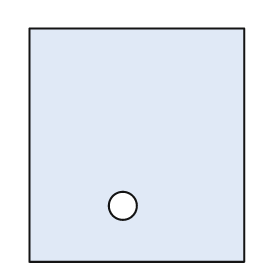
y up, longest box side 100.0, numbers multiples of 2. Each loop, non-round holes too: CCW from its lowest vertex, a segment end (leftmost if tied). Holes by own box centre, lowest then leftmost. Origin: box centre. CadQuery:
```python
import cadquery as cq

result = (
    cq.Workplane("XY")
    .moveTo(-46.0, -50.0)
    .lineTo(46.0, -50.0)
    .lineTo(46.0, 50.0)
    .lineTo(-46.0, 50.0)
    .close()
    .moveTo(-6.0, -26.0)
    .circle(6.0)
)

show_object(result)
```